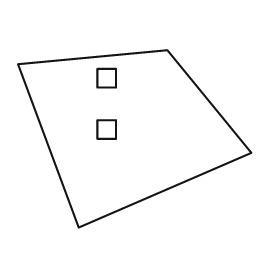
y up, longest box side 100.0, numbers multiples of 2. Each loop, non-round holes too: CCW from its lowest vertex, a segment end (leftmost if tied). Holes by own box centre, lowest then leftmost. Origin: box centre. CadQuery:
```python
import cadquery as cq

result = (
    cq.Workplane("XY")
    .moveTo(-24.0, -38.0)
    .lineTo(50.0, -6.0)
    .lineTo(14.0, 38.0)
    .lineTo(-50.0, 32.0)
    .close()
    .moveTo(-16.0, 0.0)
    .lineTo(-8.0, 0.0)
    .lineTo(-8.0, 8.0)
    .lineTo(-16.0, 8.0)
    .close()
    .moveTo(-16.0, 22.0)
    .lineTo(-8.0, 22.0)
    .lineTo(-8.0, 30.0)
    .lineTo(-16.0, 30.0)
    .close()
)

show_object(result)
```